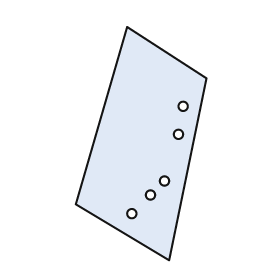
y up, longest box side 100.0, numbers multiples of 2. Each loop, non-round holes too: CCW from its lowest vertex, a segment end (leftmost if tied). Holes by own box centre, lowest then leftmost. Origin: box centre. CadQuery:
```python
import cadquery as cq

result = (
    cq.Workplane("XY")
    .moveTo(12.0, -50.0)
    .lineTo(28.0, 28.0)
    .lineTo(-6.0, 50.0)
    .lineTo(-28.0, -26.0)
    .close()
    .moveTo(-4.0, -30.0)
    .circle(2.0)
    .moveTo(4.0, -22.0)
    .circle(2.0)
    .moveTo(10.0, -16.0)
    .circle(2.0)
    .moveTo(16.0, 4.0)
    .circle(2.0)
    .moveTo(18.0, 16.0)
    .circle(2.0)
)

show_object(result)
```